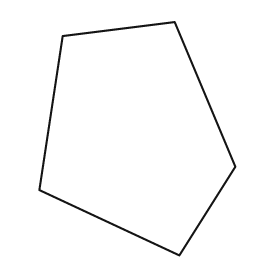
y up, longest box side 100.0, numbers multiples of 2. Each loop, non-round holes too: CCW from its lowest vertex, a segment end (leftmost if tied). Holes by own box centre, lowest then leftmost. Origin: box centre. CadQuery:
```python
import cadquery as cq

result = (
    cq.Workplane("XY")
    .moveTo(18.0, -50.0)
    .lineTo(42.0, -12.0)
    .lineTo(16.0, 50.0)
    .lineTo(-32.0, 44.0)
    .lineTo(-42.0, -22.0)
    .close()
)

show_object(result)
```